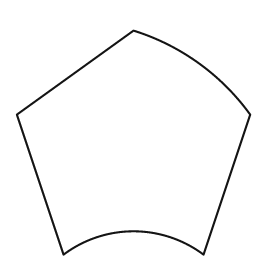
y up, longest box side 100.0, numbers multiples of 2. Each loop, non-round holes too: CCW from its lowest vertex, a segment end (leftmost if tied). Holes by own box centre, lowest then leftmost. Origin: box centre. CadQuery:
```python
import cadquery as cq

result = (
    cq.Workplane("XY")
    .moveTo(-30.0, -48.0)
    .threePointArc((0.0, -38.0), (30.0, -48.0))
    .lineTo(50.0, 12.0)
    .threePointArc((28.0, 34.0), (0.0, 48.0))
    .lineTo(-50.0, 12.0)
    .close()
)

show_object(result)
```